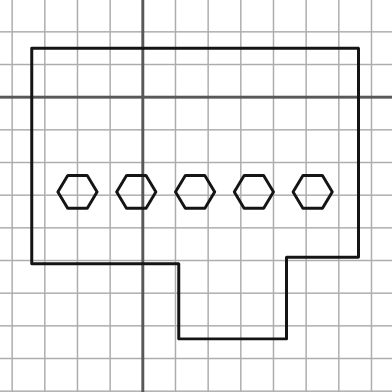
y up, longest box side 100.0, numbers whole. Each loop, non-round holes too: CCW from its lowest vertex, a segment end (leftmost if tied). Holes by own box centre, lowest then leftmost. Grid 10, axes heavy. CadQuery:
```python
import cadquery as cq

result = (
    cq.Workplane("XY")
    .moveTo(11.0, -74.0)
    .lineTo(44.0, -74.0)
    .lineTo(44.0, -49.0)
    .lineTo(66.0, -49.0)
    .lineTo(66.0, 15.0)
    .lineTo(-34.0, 15.0)
    .lineTo(-34.0, -51.0)
    .lineTo(11.0, -51.0)
    .close()
    .moveTo(-23.0, -34.0)
    .lineTo(-17.0, -34.0)
    .lineTo(-14.0, -29.0)
    .lineTo(-17.0, -24.0)
    .lineTo(-23.0, -24.0)
    .lineTo(-26.0, -29.0)
    .close()
    .moveTo(-5.0, -34.0)
    .lineTo(1.0, -34.0)
    .lineTo(4.0, -29.0)
    .lineTo(1.0, -24.0)
    .lineTo(-5.0, -24.0)
    .lineTo(-8.0, -29.0)
    .close()
    .moveTo(13.0, -34.0)
    .lineTo(19.0, -34.0)
    .lineTo(22.0, -29.0)
    .lineTo(19.0, -24.0)
    .lineTo(13.0, -24.0)
    .lineTo(10.0, -29.0)
    .close()
    .moveTo(31.0, -34.0)
    .lineTo(37.0, -34.0)
    .lineTo(40.0, -29.0)
    .lineTo(37.0, -24.0)
    .lineTo(31.0, -24.0)
    .lineTo(28.0, -29.0)
    .close()
    .moveTo(49.0, -34.0)
    .lineTo(55.0, -34.0)
    .lineTo(58.0, -29.0)
    .lineTo(55.0, -24.0)
    .lineTo(49.0, -24.0)
    .lineTo(46.0, -29.0)
    .close()
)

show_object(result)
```